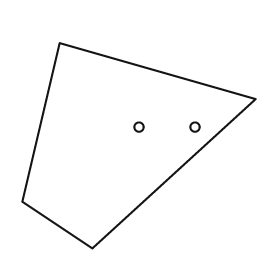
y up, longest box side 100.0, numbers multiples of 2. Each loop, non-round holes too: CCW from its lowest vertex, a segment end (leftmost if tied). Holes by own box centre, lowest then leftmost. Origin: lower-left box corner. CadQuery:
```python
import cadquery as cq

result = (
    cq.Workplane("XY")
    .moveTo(30.0, 0.0)
    .lineTo(100.0, 64.0)
    .lineTo(16.0, 88.0)
    .lineTo(0.0, 20.0)
    .close()
    .moveTo(50.0, 52.0)
    .circle(2.0)
    .moveTo(74.0, 52.0)
    .circle(2.0)
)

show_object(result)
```